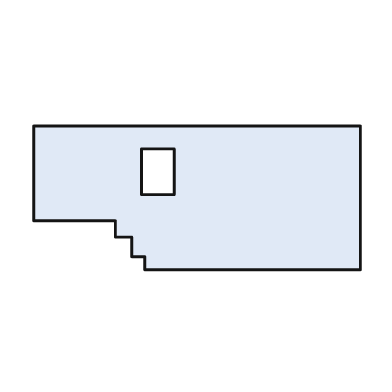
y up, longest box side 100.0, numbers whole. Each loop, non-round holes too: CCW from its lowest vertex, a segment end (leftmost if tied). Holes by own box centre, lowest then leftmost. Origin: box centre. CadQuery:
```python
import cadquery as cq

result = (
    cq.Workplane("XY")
    .moveTo(-16.0, -22.0)
    .lineTo(50.0, -22.0)
    .lineTo(50.0, 22.0)
    .lineTo(-50.0, 22.0)
    .lineTo(-50.0, -7.0)
    .lineTo(-25.0, -7.0)
    .lineTo(-25.0, -12.0)
    .lineTo(-20.0, -12.0)
    .lineTo(-20.0, -18.0)
    .lineTo(-16.0, -18.0)
    .close()
    .moveTo(-17.0, 1.0)
    .lineTo(-7.0, 1.0)
    .lineTo(-7.0, 15.0)
    .lineTo(-17.0, 15.0)
    .close()
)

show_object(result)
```